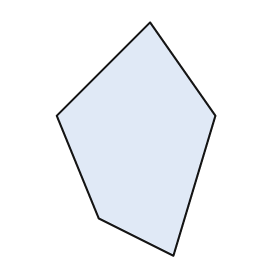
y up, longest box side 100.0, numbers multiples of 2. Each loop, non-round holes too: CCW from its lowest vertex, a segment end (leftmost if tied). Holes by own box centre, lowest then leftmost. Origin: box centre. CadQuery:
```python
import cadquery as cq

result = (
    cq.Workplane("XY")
    .moveTo(16.0, -50.0)
    .lineTo(34.0, 10.0)
    .lineTo(6.0, 50.0)
    .lineTo(-34.0, 10.0)
    .lineTo(-16.0, -34.0)
    .close()
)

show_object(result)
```